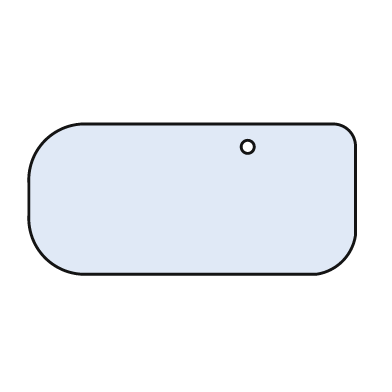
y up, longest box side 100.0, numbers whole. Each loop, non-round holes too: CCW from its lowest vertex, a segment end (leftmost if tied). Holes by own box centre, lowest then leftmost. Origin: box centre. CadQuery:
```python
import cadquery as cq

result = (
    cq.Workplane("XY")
    .moveTo(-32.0, -23.0)
    .lineTo(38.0, -23.0)
    .threePointArc((46.0, -19.0), (50.0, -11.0))
    .lineTo(50.0, 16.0)
    .threePointArc((48.0, 21.0), (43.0, 23.0))
    .lineTo(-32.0, 23.0)
    .threePointArc((-45.0, 18.0), (-50.0, 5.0))
    .lineTo(-50.0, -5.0)
    .threePointArc((-45.0, -18.0), (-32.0, -23.0))
    .close()
    .moveTo(17.0, 16.0)
    .circle(2.0)
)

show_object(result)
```